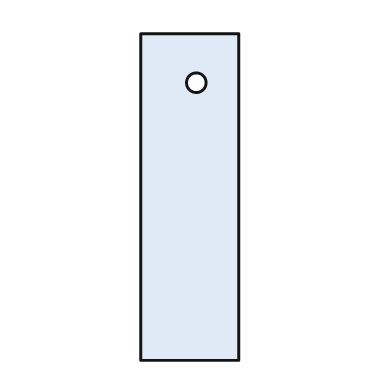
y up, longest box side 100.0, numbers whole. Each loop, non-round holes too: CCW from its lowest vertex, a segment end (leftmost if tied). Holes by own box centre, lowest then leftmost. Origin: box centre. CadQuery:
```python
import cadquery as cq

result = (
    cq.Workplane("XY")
    .moveTo(-15.0, -50.0)
    .lineTo(15.0, -50.0)
    .lineTo(15.0, 50.0)
    .lineTo(-15.0, 50.0)
    .close()
    .moveTo(2.0, 35.0)
    .circle(3.0)
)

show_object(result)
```